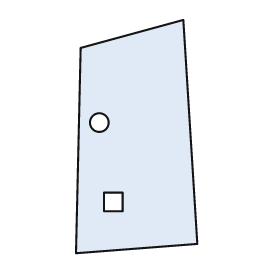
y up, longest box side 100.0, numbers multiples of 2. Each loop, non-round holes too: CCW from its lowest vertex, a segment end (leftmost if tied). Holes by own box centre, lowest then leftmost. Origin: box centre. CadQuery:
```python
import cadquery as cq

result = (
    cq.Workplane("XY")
    .moveTo(-26.0, -50.0)
    .lineTo(26.0, -46.0)
    .lineTo(20.0, 50.0)
    .lineTo(-24.0, 38.0)
    .close()
    .moveTo(-14.0, -32.0)
    .lineTo(-6.0, -32.0)
    .lineTo(-6.0, -24.0)
    .lineTo(-14.0, -24.0)
    .close()
    .moveTo(-16.0, 6.0)
    .circle(4.0)
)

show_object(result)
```